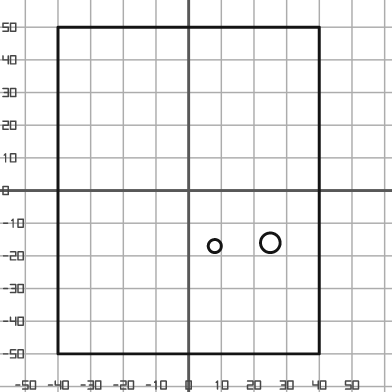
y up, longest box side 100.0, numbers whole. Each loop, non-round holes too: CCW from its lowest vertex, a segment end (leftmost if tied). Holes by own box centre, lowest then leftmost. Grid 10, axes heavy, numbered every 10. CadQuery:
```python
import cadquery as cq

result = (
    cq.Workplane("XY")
    .moveTo(-40.0, -50.0)
    .lineTo(40.0, -50.0)
    .lineTo(40.0, 50.0)
    .lineTo(-40.0, 50.0)
    .close()
    .moveTo(8.0, -17.0)
    .circle(2.0)
    .moveTo(25.0, -16.0)
    .circle(3.0)
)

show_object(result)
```